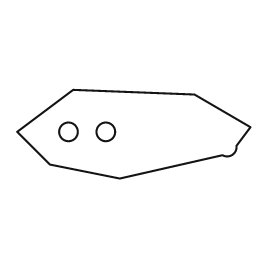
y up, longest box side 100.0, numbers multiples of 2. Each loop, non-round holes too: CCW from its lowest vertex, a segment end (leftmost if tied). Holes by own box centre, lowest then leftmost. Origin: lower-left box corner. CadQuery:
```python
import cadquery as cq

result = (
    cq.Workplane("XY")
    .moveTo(44.0, 0.0)
    .lineTo(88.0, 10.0)
    .threePointArc((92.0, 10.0), (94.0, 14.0))
    .lineTo(100.0, 22.0)
    .lineTo(76.0, 36.0)
    .lineTo(24.0, 38.0)
    .lineTo(0.0, 20.0)
    .lineTo(14.0, 6.0)
    .close()
    .moveTo(22.0, 20.0)
    .circle(4.0)
    .moveTo(38.0, 20.0)
    .circle(4.0)
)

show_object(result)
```